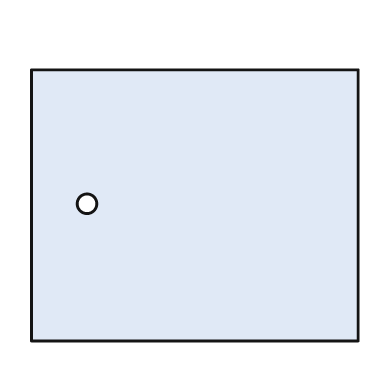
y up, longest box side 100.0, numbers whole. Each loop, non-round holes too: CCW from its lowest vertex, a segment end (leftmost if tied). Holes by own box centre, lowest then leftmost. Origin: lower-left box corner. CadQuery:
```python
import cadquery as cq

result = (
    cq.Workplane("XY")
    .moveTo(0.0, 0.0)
    .lineTo(100.0, 0.0)
    .lineTo(100.0, 83.0)
    .lineTo(0.0, 83.0)
    .close()
    .moveTo(17.0, 42.0)
    .circle(3.0)
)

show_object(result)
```